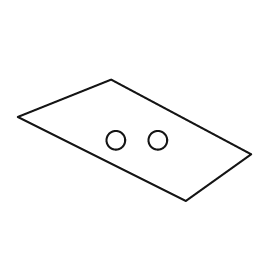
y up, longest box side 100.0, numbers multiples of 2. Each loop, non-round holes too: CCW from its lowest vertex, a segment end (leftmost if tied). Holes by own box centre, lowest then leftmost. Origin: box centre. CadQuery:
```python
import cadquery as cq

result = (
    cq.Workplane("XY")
    .moveTo(22.0, -26.0)
    .lineTo(50.0, -6.0)
    .lineTo(-10.0, 26.0)
    .lineTo(-50.0, 10.0)
    .close()
    .moveTo(-8.0, 0.0)
    .circle(4.0)
    .moveTo(10.0, 0.0)
    .circle(4.0)
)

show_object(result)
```